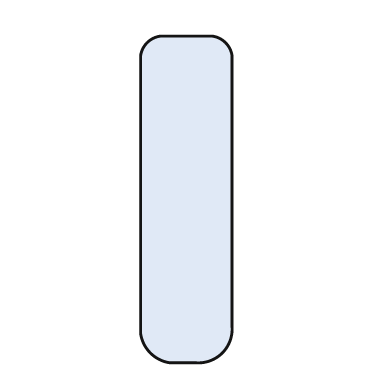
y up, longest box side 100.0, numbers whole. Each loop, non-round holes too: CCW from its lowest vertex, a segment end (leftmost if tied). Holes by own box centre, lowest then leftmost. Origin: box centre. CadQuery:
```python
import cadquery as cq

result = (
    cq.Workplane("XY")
    .moveTo(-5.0, -50.0)
    .lineTo(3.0, -50.0)
    .threePointArc((11.0, -47.0), (14.0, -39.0))
    .lineTo(14.0, 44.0)
    .threePointArc((12.0, 48.0), (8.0, 50.0))
    .lineTo(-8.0, 50.0)
    .threePointArc((-12.0, 48.0), (-14.0, 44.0))
    .lineTo(-14.0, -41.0)
    .threePointArc((-11.0, -47.0), (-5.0, -50.0))
    .close()
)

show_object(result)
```